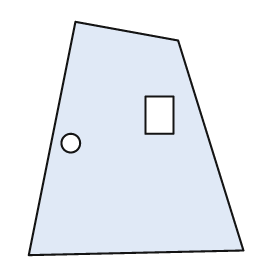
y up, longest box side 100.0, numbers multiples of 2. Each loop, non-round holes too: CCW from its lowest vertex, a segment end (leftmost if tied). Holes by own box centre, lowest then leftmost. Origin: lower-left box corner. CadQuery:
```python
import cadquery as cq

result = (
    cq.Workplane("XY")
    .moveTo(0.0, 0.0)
    .lineTo(92.0, 2.0)
    .lineTo(64.0, 92.0)
    .lineTo(20.0, 100.0)
    .close()
    .moveTo(18.0, 48.0)
    .circle(4.0)
    .moveTo(50.0, 52.0)
    .lineTo(62.0, 52.0)
    .lineTo(62.0, 68.0)
    .lineTo(50.0, 68.0)
    .close()
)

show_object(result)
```